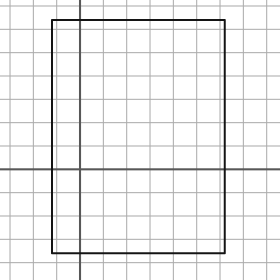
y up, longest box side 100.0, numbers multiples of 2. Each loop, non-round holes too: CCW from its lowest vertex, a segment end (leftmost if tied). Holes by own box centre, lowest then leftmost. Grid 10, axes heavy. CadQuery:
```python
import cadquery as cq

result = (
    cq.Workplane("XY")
    .moveTo(-12.0, -36.0)
    .lineTo(62.0, -36.0)
    .lineTo(62.0, 64.0)
    .lineTo(-12.0, 64.0)
    .close()
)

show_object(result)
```